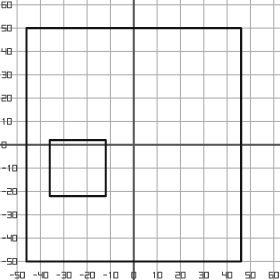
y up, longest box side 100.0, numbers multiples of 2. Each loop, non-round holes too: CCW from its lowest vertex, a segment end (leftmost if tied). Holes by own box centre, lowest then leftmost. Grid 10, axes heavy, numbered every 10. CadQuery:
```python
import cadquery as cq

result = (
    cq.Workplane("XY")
    .moveTo(-46.0, -50.0)
    .lineTo(46.0, -50.0)
    .lineTo(46.0, 50.0)
    .lineTo(-46.0, 50.0)
    .close()
    .moveTo(-36.0, -22.0)
    .lineTo(-12.0, -22.0)
    .lineTo(-12.0, 2.0)
    .lineTo(-36.0, 2.0)
    .close()
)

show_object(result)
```